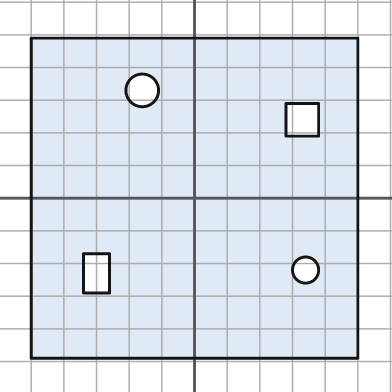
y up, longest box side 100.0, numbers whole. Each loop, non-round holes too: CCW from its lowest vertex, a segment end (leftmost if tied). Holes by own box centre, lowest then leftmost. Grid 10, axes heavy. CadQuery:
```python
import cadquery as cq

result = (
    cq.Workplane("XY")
    .moveTo(-50.0, -49.0)
    .lineTo(50.0, -49.0)
    .lineTo(50.0, 49.0)
    .lineTo(-50.0, 49.0)
    .close()
    .moveTo(-34.0, -29.0)
    .lineTo(-26.0, -29.0)
    .lineTo(-26.0, -17.0)
    .lineTo(-34.0, -17.0)
    .close()
    .moveTo(34.0, -22.0)
    .circle(4.0)
    .moveTo(28.0, 19.0)
    .lineTo(38.0, 19.0)
    .lineTo(38.0, 29.0)
    .lineTo(28.0, 29.0)
    .close()
    .moveTo(-16.0, 33.0)
    .circle(5.0)
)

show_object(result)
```